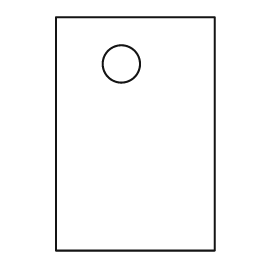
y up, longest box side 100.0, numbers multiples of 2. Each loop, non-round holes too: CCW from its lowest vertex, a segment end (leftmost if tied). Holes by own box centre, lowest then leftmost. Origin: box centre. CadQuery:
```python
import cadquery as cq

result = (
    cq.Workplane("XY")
    .moveTo(-34.0, -50.0)
    .lineTo(34.0, -50.0)
    .lineTo(34.0, 50.0)
    .lineTo(-34.0, 50.0)
    .close()
    .moveTo(-6.0, 30.0)
    .circle(8.0)
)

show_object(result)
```